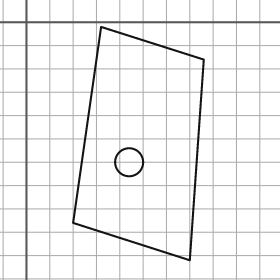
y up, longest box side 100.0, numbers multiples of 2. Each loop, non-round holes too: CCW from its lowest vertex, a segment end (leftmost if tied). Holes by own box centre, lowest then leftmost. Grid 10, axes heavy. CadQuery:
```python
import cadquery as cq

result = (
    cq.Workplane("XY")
    .moveTo(70.0, -102.0)
    .lineTo(76.0, -16.0)
    .lineTo(32.0, -2.0)
    .lineTo(20.0, -86.0)
    .close()
    .moveTo(44.0, -60.0)
    .circle(6.0)
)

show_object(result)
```